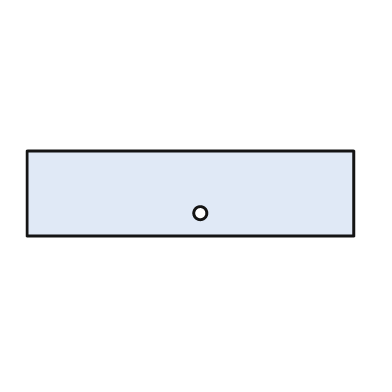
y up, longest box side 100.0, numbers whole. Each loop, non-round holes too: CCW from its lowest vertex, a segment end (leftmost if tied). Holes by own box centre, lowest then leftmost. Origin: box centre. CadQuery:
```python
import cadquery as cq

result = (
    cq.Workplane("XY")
    .moveTo(-50.0, -13.0)
    .lineTo(50.0, -13.0)
    .lineTo(50.0, 13.0)
    .lineTo(-50.0, 13.0)
    .close()
    .moveTo(3.0, -6.0)
    .circle(2.0)
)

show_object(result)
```